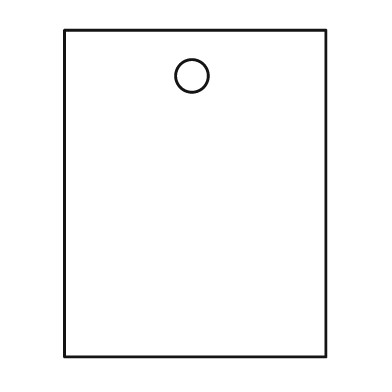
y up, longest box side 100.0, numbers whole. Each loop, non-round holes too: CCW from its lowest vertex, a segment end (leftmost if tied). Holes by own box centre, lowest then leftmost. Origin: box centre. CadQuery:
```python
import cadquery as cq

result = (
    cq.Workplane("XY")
    .moveTo(-40.0, -50.0)
    .lineTo(40.0, -50.0)
    .lineTo(40.0, 50.0)
    .lineTo(-40.0, 50.0)
    .close()
    .moveTo(-1.0, 36.0)
    .circle(5.0)
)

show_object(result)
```